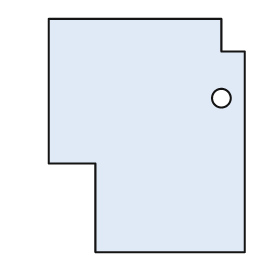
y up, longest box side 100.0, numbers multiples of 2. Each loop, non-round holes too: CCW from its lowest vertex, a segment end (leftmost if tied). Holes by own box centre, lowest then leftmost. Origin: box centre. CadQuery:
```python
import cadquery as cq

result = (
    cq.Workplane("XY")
    .moveTo(-22.0, -50.0)
    .lineTo(42.0, -50.0)
    .lineTo(42.0, 36.0)
    .lineTo(32.0, 36.0)
    .lineTo(32.0, 50.0)
    .lineTo(-42.0, 50.0)
    .lineTo(-42.0, -12.0)
    .lineTo(-22.0, -12.0)
    .close()
    .moveTo(32.0, 16.0)
    .circle(4.0)
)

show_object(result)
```